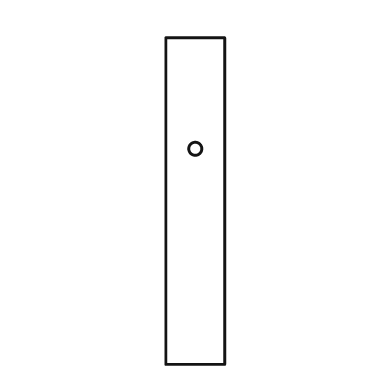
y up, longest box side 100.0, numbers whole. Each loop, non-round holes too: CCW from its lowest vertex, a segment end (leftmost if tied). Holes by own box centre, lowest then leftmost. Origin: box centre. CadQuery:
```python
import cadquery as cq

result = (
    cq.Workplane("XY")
    .moveTo(-9.0, -50.0)
    .lineTo(9.0, -50.0)
    .lineTo(9.0, 50.0)
    .lineTo(-9.0, 50.0)
    .close()
    .moveTo(0.0, 16.0)
    .circle(2.0)
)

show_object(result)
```